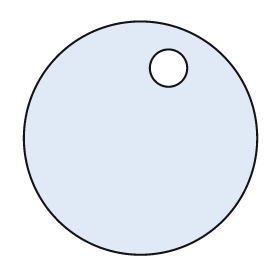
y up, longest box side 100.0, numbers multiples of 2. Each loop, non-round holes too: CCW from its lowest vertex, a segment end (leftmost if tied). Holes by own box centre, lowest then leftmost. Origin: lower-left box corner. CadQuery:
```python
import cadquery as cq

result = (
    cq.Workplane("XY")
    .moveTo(50.0, 50.0)
    .circle(50.0)
    .moveTo(62.0, 80.0)
    .circle(8.0)
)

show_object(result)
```